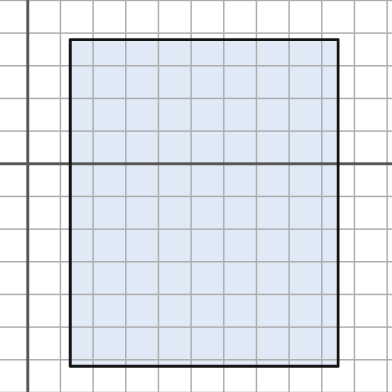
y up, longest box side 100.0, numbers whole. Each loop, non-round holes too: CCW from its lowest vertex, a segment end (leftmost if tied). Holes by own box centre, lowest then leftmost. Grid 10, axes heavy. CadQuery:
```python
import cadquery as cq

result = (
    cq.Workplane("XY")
    .moveTo(13.0, -62.0)
    .lineTo(95.0, -62.0)
    .lineTo(95.0, 38.0)
    .lineTo(13.0, 38.0)
    .close()
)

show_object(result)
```